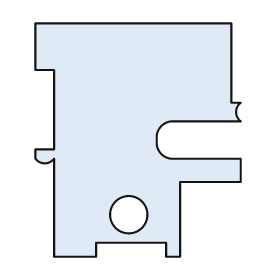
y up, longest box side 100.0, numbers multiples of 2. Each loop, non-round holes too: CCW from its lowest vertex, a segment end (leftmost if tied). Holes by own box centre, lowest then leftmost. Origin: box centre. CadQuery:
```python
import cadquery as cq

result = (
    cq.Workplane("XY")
    .moveTo(-36.0, -50.0)
    .lineTo(-18.0, -50.0)
    .lineTo(-18.0, -44.0)
    .lineTo(12.0, -44.0)
    .lineTo(12.0, -50.0)
    .lineTo(18.0, -50.0)
    .lineTo(18.0, -18.0)
    .lineTo(44.0, -18.0)
    .lineTo(44.0, -8.0)
    .lineTo(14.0, -8.0)
    .threePointArc((10.0, -6.0), (8.0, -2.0))
    .lineTo(8.0, 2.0)
    .threePointArc((10.0, 6.0), (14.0, 8.0))
    .lineTo(44.0, 8.0)
    .threePointArc((42.0, 12.0), (44.0, 16.0))
    .lineTo(40.0, 16.0)
    .lineTo(40.0, 50.0)
    .lineTo(-44.0, 50.0)
    .lineTo(-44.0, 30.0)
    .lineTo(-36.0, 30.0)
    .lineTo(-36.0, -4.0)
    .lineTo(-44.0, -4.0)
    .lineTo(-44.0, -8.0)
    .threePointArc((-40.0, -10.0), (-36.0, -8.0))
    .close()
    .moveTo(-4.0, -32.0)
    .circle(8.0)
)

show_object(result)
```